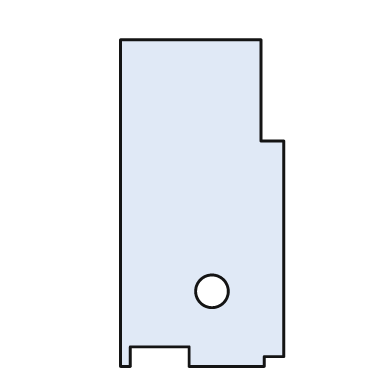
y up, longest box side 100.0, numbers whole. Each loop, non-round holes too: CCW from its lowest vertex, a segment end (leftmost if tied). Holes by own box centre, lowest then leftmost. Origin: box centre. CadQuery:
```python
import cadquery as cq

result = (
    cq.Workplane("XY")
    .moveTo(-25.0, -50.0)
    .lineTo(-22.0, -50.0)
    .lineTo(-22.0, -44.0)
    .lineTo(-4.0, -44.0)
    .lineTo(-4.0, -50.0)
    .lineTo(19.0, -50.0)
    .lineTo(19.0, -47.0)
    .lineTo(25.0, -47.0)
    .lineTo(25.0, 19.0)
    .lineTo(18.0, 19.0)
    .lineTo(18.0, 50.0)
    .lineTo(-25.0, 50.0)
    .close()
    .moveTo(3.0, -27.0)
    .circle(5.0)
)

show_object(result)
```